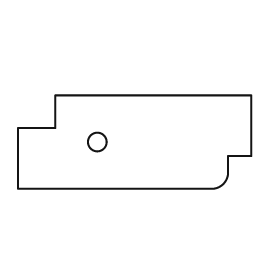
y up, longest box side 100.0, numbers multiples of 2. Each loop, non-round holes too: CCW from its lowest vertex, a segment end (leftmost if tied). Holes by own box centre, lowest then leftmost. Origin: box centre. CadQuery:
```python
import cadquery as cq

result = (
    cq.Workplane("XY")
    .moveTo(-50.0, -20.0)
    .lineTo(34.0, -20.0)
    .threePointArc((38.0, -18.0), (40.0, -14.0))
    .lineTo(40.0, -6.0)
    .lineTo(50.0, -6.0)
    .lineTo(50.0, 20.0)
    .lineTo(-34.0, 20.0)
    .lineTo(-34.0, 6.0)
    .lineTo(-50.0, 6.0)
    .close()
    .moveTo(-16.0, 0.0)
    .circle(4.0)
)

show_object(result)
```